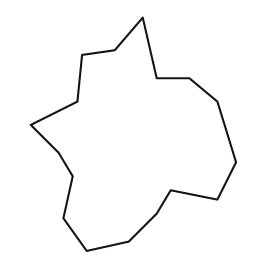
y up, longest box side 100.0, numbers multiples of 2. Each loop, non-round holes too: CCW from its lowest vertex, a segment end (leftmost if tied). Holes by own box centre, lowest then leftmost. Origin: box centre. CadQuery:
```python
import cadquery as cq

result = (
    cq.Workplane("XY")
    .moveTo(-20.0, -50.0)
    .lineTo(-2.0, -46.0)
    .lineTo(10.0, -34.0)
    .lineTo(16.0, -24.0)
    .lineTo(36.0, -28.0)
    .lineTo(44.0, -12.0)
    .lineTo(36.0, 14.0)
    .lineTo(24.0, 24.0)
    .lineTo(10.0, 24.0)
    .lineTo(4.0, 50.0)
    .lineTo(-8.0, 36.0)
    .lineTo(-22.0, 34.0)
    .lineTo(-24.0, 14.0)
    .lineTo(-44.0, 4.0)
    .lineTo(-32.0, -8.0)
    .lineTo(-26.0, -18.0)
    .lineTo(-30.0, -36.0)
    .close()
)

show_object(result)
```